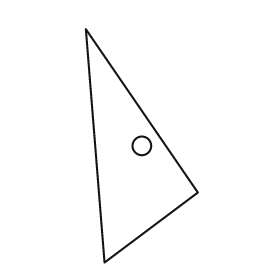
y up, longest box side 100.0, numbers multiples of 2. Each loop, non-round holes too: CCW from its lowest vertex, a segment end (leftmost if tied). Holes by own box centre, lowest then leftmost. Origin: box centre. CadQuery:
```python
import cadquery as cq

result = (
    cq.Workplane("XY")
    .moveTo(-16.0, -50.0)
    .lineTo(24.0, -20.0)
    .lineTo(-24.0, 50.0)
    .close()
    .moveTo(0.0, 0.0)
    .circle(4.0)
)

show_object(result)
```